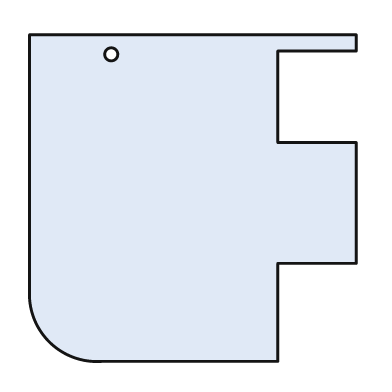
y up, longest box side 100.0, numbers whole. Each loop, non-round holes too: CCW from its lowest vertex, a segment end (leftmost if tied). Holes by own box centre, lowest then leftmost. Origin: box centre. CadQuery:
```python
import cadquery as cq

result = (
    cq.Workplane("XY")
    .moveTo(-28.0, -50.0)
    .lineTo(26.0, -50.0)
    .lineTo(26.0, -20.0)
    .lineTo(50.0, -20.0)
    .lineTo(50.0, 17.0)
    .lineTo(26.0, 17.0)
    .lineTo(26.0, 45.0)
    .lineTo(50.0, 45.0)
    .lineTo(50.0, 50.0)
    .lineTo(-50.0, 50.0)
    .lineTo(-50.0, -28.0)
    .threePointArc((-44.0, -44.0), (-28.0, -50.0))
    .close()
    .moveTo(-25.0, 44.0)
    .circle(2.0)
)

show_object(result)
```